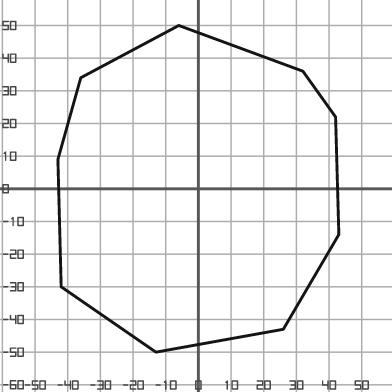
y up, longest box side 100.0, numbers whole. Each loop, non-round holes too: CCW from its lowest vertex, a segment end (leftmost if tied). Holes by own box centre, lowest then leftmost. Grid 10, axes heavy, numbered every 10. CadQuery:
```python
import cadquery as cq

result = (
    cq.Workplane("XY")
    .moveTo(-13.0, -50.0)
    .lineTo(26.0, -43.0)
    .lineTo(43.0, -14.0)
    .lineTo(42.0, 22.0)
    .lineTo(32.0, 36.0)
    .lineTo(-6.0, 50.0)
    .lineTo(-36.0, 34.0)
    .lineTo(-43.0, 9.0)
    .lineTo(-42.0, -30.0)
    .close()
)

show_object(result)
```